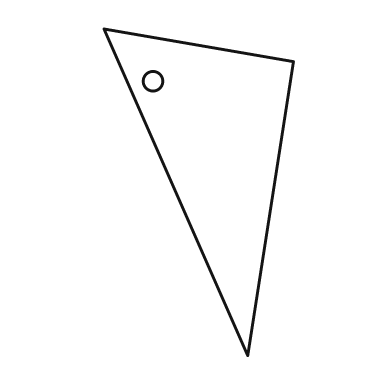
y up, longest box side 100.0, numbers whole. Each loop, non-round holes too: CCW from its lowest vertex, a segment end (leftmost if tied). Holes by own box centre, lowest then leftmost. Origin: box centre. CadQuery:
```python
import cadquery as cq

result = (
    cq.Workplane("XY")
    .moveTo(15.0, -50.0)
    .lineTo(29.0, 40.0)
    .lineTo(-29.0, 50.0)
    .close()
    .moveTo(-14.0, 34.0)
    .circle(3.0)
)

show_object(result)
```